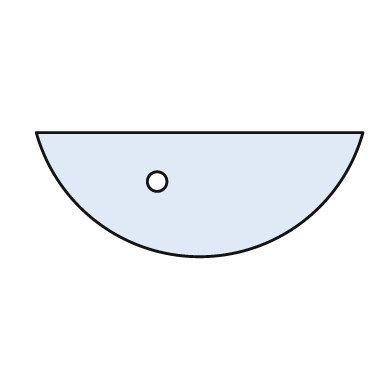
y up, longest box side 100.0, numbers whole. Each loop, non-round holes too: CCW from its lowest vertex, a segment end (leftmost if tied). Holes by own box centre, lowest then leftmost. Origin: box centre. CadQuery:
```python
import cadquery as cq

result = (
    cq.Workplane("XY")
    .moveTo(-50.0, 19.0)
    .threePointArc((0.0, -19.0), (50.0, 19.0))
    .close()
    .moveTo(-13.0, 4.0)
    .circle(3.0)
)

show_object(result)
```